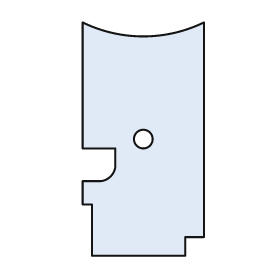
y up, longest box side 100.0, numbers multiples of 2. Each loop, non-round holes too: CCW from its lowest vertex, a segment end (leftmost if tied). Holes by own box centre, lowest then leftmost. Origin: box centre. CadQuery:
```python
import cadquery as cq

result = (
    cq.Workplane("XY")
    .moveTo(-22.0, -50.0)
    .lineTo(18.0, -50.0)
    .lineTo(18.0, -42.0)
    .lineTo(26.0, -42.0)
    .lineTo(26.0, 50.0)
    .threePointArc((0.0, 44.0), (-26.0, 50.0))
    .lineTo(-26.0, -4.0)
    .lineTo(-12.0, -4.0)
    .lineTo(-12.0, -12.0)
    .threePointArc((-14.0, -16.0), (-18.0, -18.0))
    .lineTo(-26.0, -18.0)
    .lineTo(-26.0, -28.0)
    .lineTo(-22.0, -28.0)
    .close()
    .moveTo(0.0, 0.0)
    .circle(4.0)
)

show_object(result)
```